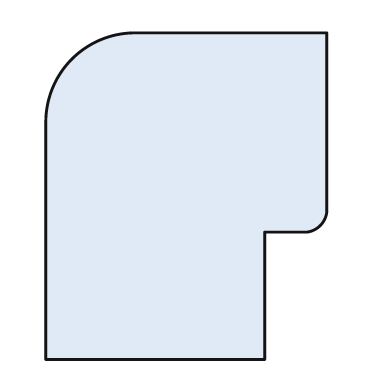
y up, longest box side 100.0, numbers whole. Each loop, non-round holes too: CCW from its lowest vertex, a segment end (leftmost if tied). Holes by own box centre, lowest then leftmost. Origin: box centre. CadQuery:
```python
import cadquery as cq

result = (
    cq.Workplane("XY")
    .moveTo(-43.0, -50.0)
    .lineTo(24.0, -50.0)
    .lineTo(24.0, -11.0)
    .lineTo(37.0, -11.0)
    .threePointArc((41.0, -9.0), (43.0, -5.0))
    .lineTo(43.0, 50.0)
    .lineTo(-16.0, 50.0)
    .threePointArc((-35.0, 42.0), (-43.0, 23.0))
    .close()
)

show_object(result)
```